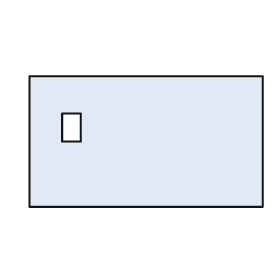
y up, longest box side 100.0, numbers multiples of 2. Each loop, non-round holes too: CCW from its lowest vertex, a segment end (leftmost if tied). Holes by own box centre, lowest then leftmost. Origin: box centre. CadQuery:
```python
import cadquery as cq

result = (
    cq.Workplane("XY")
    .moveTo(-50.0, -28.0)
    .lineTo(50.0, -28.0)
    .lineTo(50.0, 28.0)
    .lineTo(-50.0, 28.0)
    .close()
    .moveTo(-36.0, 0.0)
    .lineTo(-28.0, 0.0)
    .lineTo(-28.0, 12.0)
    .lineTo(-36.0, 12.0)
    .close()
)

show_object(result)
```